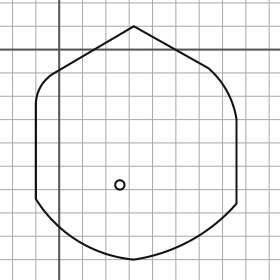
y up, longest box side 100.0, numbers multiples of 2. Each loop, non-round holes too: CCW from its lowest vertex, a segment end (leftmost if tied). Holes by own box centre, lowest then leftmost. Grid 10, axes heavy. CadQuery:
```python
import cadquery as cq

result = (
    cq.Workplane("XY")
    .moveTo(32.0, -90.0)
    .threePointArc((56.0, -82.0), (76.0, -66.0))
    .lineTo(76.0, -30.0)
    .threePointArc((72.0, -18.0), (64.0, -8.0))
    .lineTo(32.0, 10.0)
    .lineTo(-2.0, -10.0)
    .threePointArc((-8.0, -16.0), (-10.0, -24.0))
    .lineTo(-10.0, -64.0)
    .threePointArc((8.0, -82.0), (32.0, -90.0))
    .close()
    .moveTo(26.0, -58.0)
    .circle(2.0)
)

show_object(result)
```